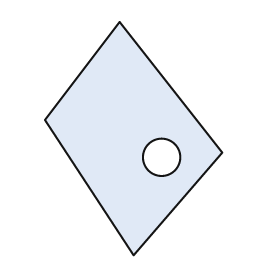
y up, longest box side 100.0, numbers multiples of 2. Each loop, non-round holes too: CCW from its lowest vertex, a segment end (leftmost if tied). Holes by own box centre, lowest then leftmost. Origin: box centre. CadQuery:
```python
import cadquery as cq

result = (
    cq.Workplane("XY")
    .moveTo(0.0, -50.0)
    .lineTo(38.0, -6.0)
    .lineTo(-6.0, 50.0)
    .lineTo(-38.0, 8.0)
    .close()
    .moveTo(12.0, -8.0)
    .circle(8.0)
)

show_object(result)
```